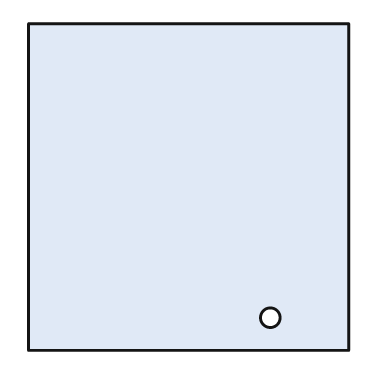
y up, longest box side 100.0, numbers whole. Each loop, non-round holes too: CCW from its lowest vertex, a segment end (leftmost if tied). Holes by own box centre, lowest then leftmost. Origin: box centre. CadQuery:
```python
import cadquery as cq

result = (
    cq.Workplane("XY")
    .moveTo(-49.0, -50.0)
    .lineTo(49.0, -50.0)
    .lineTo(49.0, 50.0)
    .lineTo(-49.0, 50.0)
    .close()
    .moveTo(25.0, -40.0)
    .circle(3.0)
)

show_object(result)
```